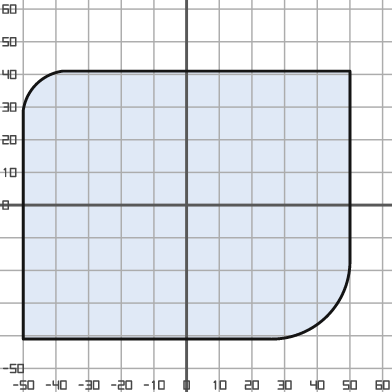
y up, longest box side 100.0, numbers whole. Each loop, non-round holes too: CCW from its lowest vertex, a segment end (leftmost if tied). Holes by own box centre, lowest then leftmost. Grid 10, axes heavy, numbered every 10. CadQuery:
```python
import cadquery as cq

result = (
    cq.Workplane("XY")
    .moveTo(-50.0, -41.0)
    .lineTo(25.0, -41.0)
    .threePointArc((43.0, -34.0), (50.0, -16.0))
    .lineTo(50.0, 41.0)
    .lineTo(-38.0, 41.0)
    .threePointArc((-46.0, 37.0), (-50.0, 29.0))
    .close()
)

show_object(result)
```